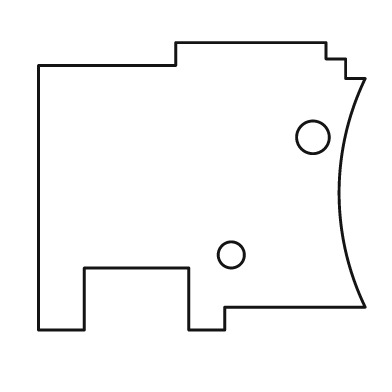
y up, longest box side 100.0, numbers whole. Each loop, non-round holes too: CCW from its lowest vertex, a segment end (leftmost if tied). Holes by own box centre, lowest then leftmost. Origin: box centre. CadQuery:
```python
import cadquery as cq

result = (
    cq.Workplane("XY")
    .moveTo(-50.0, -44.0)
    .lineTo(-36.0, -44.0)
    .lineTo(-36.0, -25.0)
    .lineTo(-4.0, -25.0)
    .lineTo(-4.0, -44.0)
    .lineTo(7.0, -44.0)
    .lineTo(7.0, -37.0)
    .lineTo(50.0, -37.0)
    .threePointArc((42.0, -2.0), (50.0, 33.0))
    .lineTo(44.0, 33.0)
    .lineTo(44.0, 39.0)
    .lineTo(38.0, 39.0)
    .lineTo(38.0, 44.0)
    .lineTo(-8.0, 44.0)
    .lineTo(-8.0, 37.0)
    .lineTo(-50.0, 37.0)
    .close()
    .moveTo(9.0, -21.0)
    .circle(4.0)
    .moveTo(34.0, 15.0)
    .circle(5.0)
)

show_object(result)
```